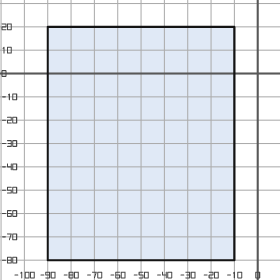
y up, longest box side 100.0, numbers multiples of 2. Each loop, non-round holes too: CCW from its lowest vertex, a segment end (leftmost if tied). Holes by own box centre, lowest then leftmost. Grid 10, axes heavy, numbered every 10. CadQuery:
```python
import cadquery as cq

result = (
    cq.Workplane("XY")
    .moveTo(-90.0, -80.0)
    .lineTo(-10.0, -80.0)
    .lineTo(-10.0, 20.0)
    .lineTo(-90.0, 20.0)
    .close()
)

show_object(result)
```